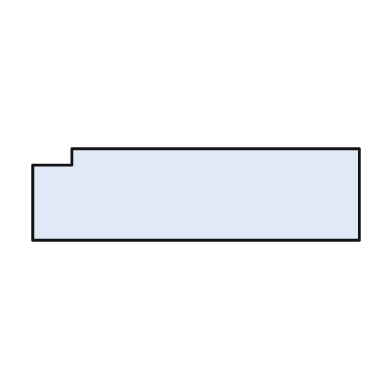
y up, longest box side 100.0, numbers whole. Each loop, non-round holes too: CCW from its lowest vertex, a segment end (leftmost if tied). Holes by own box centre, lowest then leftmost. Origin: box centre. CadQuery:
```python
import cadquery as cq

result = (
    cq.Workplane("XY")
    .moveTo(-50.0, -14.0)
    .lineTo(50.0, -14.0)
    .lineTo(50.0, 14.0)
    .lineTo(-38.0, 14.0)
    .lineTo(-38.0, 9.0)
    .lineTo(-50.0, 9.0)
    .close()
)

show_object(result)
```